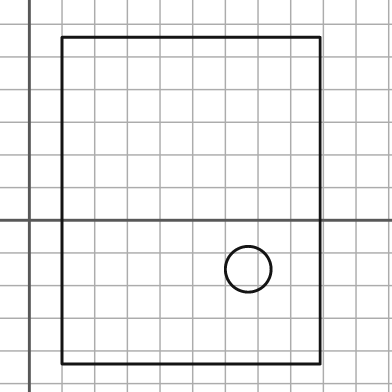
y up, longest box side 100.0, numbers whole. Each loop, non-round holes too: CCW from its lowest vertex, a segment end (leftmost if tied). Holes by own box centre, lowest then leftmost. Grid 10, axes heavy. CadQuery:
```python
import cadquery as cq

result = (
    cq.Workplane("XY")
    .moveTo(10.0, -44.0)
    .lineTo(89.0, -44.0)
    .lineTo(89.0, 56.0)
    .lineTo(10.0, 56.0)
    .close()
    .moveTo(67.0, -15.0)
    .circle(7.0)
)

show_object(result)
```